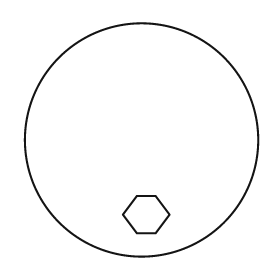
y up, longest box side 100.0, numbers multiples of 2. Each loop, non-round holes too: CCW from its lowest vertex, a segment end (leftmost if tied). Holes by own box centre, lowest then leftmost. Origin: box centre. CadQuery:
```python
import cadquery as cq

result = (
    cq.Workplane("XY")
    .moveTo(0.0, 0.0)
    .circle(50.0)
    .moveTo(-2.0, -40.0)
    .lineTo(6.0, -40.0)
    .lineTo(12.0, -32.0)
    .lineTo(6.0, -24.0)
    .lineTo(-2.0, -24.0)
    .lineTo(-8.0, -32.0)
    .close()
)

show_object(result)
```